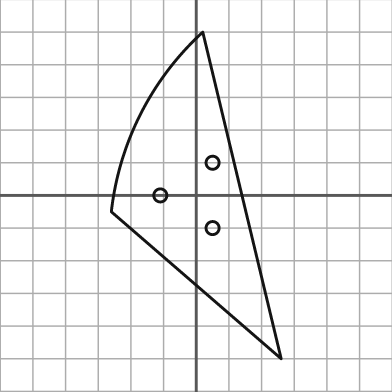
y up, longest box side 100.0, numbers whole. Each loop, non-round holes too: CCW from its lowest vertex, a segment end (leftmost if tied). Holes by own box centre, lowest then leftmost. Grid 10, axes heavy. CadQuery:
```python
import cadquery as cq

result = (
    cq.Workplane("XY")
    .moveTo(26.0, -50.0)
    .lineTo(2.0, 50.0)
    .threePointArc((-17.0, 25.0), (-26.0, -5.0))
    .close()
    .moveTo(5.0, -10.0)
    .circle(2.0)
    .moveTo(-11.0, 0.0)
    .circle(2.0)
    .moveTo(5.0, 10.0)
    .circle(2.0)
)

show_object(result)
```